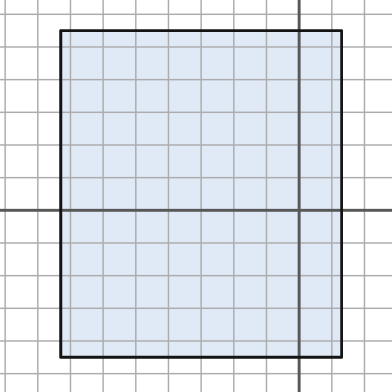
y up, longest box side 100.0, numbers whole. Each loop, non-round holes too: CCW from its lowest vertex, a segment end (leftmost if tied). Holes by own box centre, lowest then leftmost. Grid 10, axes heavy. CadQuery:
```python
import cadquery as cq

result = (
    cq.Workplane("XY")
    .moveTo(-73.0, -45.0)
    .lineTo(13.0, -45.0)
    .lineTo(13.0, 55.0)
    .lineTo(-73.0, 55.0)
    .close()
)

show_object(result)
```